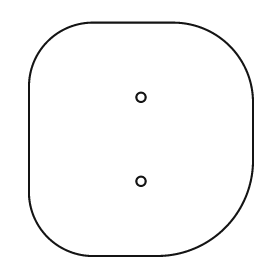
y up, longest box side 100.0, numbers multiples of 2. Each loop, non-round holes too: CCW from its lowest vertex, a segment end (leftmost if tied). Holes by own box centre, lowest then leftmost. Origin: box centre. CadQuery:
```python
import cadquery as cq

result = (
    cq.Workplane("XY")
    .moveTo(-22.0, -50.0)
    .lineTo(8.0, -50.0)
    .threePointArc((36.0, -38.0), (48.0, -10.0))
    .lineTo(48.0, 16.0)
    .threePointArc((38.0, 40.0), (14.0, 50.0))
    .lineTo(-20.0, 50.0)
    .threePointArc((-40.0, 42.0), (-48.0, 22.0))
    .lineTo(-48.0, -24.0)
    .threePointArc((-40.0, -42.0), (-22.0, -50.0))
    .close()
    .moveTo(0.0, -18.0)
    .circle(2.0)
    .moveTo(0.0, 18.0)
    .circle(2.0)
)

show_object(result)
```